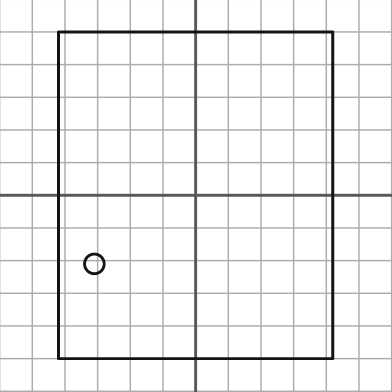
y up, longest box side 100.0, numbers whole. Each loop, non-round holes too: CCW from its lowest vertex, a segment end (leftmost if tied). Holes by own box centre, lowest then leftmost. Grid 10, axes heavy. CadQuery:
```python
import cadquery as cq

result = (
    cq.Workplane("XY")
    .moveTo(-42.0, -50.0)
    .lineTo(42.0, -50.0)
    .lineTo(42.0, 50.0)
    .lineTo(-42.0, 50.0)
    .close()
    .moveTo(-31.0, -21.0)
    .circle(3.0)
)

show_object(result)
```